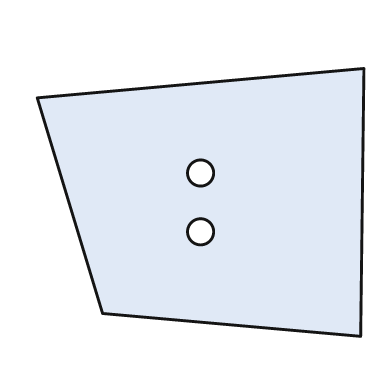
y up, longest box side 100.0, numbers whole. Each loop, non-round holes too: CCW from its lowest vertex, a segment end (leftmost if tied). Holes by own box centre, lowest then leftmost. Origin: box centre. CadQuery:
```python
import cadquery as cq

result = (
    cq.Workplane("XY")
    .moveTo(49.0, -41.0)
    .lineTo(50.0, 41.0)
    .lineTo(-50.0, 32.0)
    .lineTo(-30.0, -34.0)
    .close()
    .moveTo(0.0, -9.0)
    .circle(4.0)
    .moveTo(0.0, 9.0)
    .circle(4.0)
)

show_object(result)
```